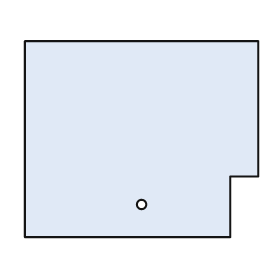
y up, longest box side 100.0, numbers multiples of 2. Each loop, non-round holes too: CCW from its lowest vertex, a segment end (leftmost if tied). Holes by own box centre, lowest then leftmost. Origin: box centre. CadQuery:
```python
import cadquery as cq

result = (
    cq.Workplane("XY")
    .moveTo(-50.0, -42.0)
    .lineTo(38.0, -42.0)
    .lineTo(38.0, -16.0)
    .lineTo(50.0, -16.0)
    .lineTo(50.0, 42.0)
    .lineTo(-50.0, 42.0)
    .close()
    .moveTo(0.0, -28.0)
    .circle(2.0)
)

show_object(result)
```